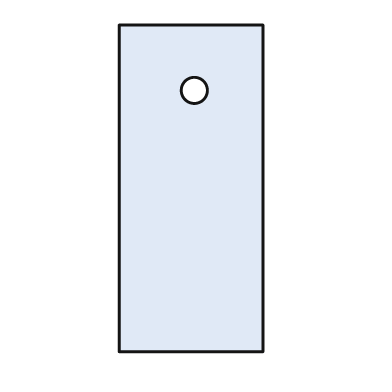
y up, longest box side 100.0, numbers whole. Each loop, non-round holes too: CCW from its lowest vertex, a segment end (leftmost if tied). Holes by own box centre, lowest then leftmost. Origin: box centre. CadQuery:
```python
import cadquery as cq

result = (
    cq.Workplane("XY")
    .moveTo(-22.0, -50.0)
    .lineTo(22.0, -50.0)
    .lineTo(22.0, 50.0)
    .lineTo(-22.0, 50.0)
    .close()
    .moveTo(1.0, 30.0)
    .circle(4.0)
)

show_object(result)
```